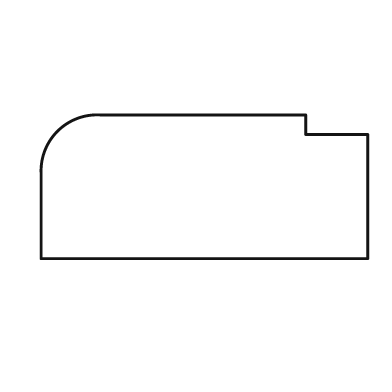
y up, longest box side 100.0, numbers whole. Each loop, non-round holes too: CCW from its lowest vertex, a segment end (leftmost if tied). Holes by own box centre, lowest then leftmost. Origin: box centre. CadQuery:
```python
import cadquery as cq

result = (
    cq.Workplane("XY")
    .moveTo(-50.0, -22.0)
    .lineTo(50.0, -22.0)
    .lineTo(50.0, 16.0)
    .lineTo(31.0, 16.0)
    .lineTo(31.0, 22.0)
    .lineTo(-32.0, 22.0)
    .threePointArc((-45.0, 17.0), (-50.0, 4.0))
    .close()
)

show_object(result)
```